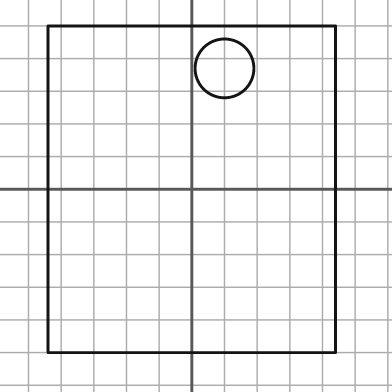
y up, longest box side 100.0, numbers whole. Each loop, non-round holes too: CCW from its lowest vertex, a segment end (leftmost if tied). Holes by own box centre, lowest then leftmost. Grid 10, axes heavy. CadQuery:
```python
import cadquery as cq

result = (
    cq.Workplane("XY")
    .moveTo(-44.0, -50.0)
    .lineTo(44.0, -50.0)
    .lineTo(44.0, 50.0)
    .lineTo(-44.0, 50.0)
    .close()
    .moveTo(10.0, 37.0)
    .circle(9.0)
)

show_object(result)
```